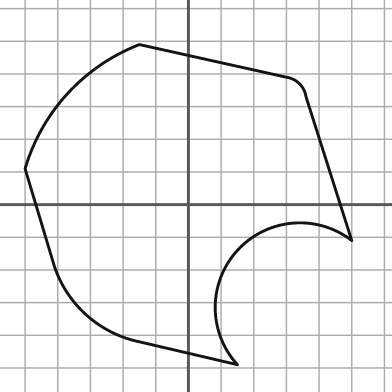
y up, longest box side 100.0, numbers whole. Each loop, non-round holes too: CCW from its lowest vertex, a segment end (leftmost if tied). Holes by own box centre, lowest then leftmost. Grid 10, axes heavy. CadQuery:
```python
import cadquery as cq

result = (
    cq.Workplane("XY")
    .moveTo(15.0, -49.0)
    .threePointArc((15.0, -14.0), (50.0, -11.0))
    .lineTo(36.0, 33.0)
    .threePointArc((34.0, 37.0), (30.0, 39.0))
    .lineTo(-15.0, 49.0)
    .threePointArc((-37.0, 34.0), (-50.0, 11.0))
    .lineTo(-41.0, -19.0)
    .threePointArc((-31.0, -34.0), (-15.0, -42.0))
    .close()
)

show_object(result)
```